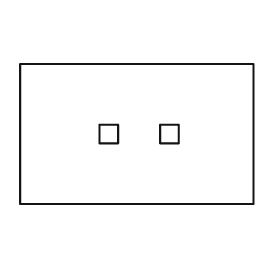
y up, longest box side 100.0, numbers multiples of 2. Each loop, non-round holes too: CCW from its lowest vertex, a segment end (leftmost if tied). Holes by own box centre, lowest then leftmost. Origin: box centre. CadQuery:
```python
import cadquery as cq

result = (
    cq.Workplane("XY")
    .moveTo(-50.0, -30.0)
    .lineTo(50.0, -30.0)
    .lineTo(50.0, 30.0)
    .lineTo(-50.0, 30.0)
    .close()
    .moveTo(-16.0, -4.0)
    .lineTo(-8.0, -4.0)
    .lineTo(-8.0, 4.0)
    .lineTo(-16.0, 4.0)
    .close()
    .moveTo(10.0, -4.0)
    .lineTo(18.0, -4.0)
    .lineTo(18.0, 4.0)
    .lineTo(10.0, 4.0)
    .close()
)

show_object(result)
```